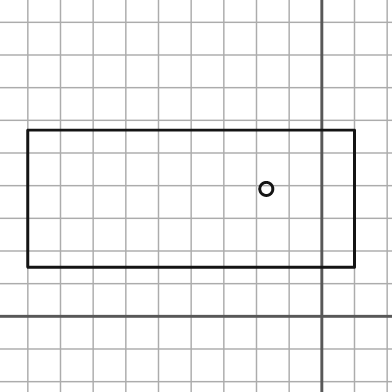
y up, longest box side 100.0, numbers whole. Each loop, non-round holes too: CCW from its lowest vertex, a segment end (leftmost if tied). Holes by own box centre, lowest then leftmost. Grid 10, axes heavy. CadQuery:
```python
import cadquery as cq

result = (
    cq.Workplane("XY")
    .moveTo(-90.0, 15.0)
    .lineTo(10.0, 15.0)
    .lineTo(10.0, 57.0)
    .lineTo(-90.0, 57.0)
    .close()
    .moveTo(-17.0, 39.0)
    .circle(2.0)
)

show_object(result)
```